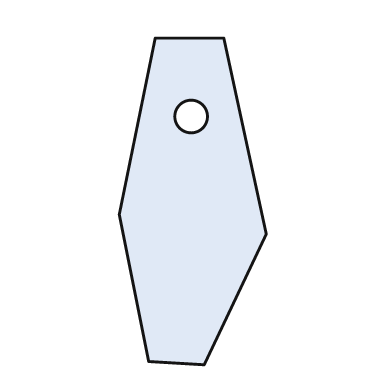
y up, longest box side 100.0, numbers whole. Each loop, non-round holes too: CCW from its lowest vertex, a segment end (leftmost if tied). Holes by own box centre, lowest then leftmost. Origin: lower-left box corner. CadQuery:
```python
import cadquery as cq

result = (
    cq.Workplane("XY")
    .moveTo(26.0, 0.0)
    .lineTo(45.0, 40.0)
    .lineTo(32.0, 100.0)
    .lineTo(11.0, 100.0)
    .lineTo(0.0, 46.0)
    .lineTo(9.0, 1.0)
    .close()
    .moveTo(22.0, 76.0)
    .circle(5.0)
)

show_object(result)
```